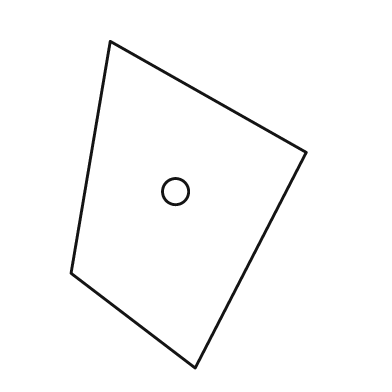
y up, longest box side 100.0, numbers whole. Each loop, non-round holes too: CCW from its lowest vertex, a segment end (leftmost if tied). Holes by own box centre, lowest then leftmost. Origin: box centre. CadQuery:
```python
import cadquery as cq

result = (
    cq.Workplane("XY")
    .moveTo(2.0, -50.0)
    .lineTo(36.0, 16.0)
    .lineTo(-24.0, 50.0)
    .lineTo(-36.0, -21.0)
    .close()
    .moveTo(-4.0, 4.0)
    .circle(4.0)
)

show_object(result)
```